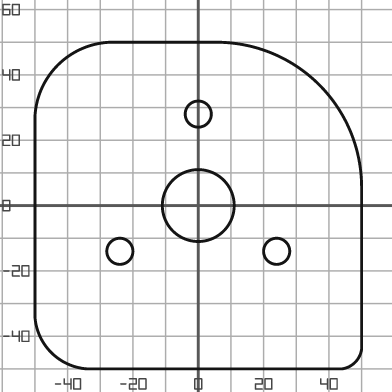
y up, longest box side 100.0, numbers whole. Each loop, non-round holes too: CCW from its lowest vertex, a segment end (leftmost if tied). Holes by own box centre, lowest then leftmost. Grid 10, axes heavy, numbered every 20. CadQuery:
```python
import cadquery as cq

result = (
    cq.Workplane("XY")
    .moveTo(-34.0, -50.0)
    .lineTo(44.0, -50.0)
    .threePointArc((48.0, -48.0), (50.0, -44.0))
    .lineTo(50.0, 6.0)
    .threePointArc((37.0, 37.0), (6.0, 50.0))
    .lineTo(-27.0, 50.0)
    .threePointArc((-43.0, 43.0), (-50.0, 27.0))
    .lineTo(-50.0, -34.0)
    .threePointArc((-45.0, -45.0), (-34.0, -50.0))
    .close()
    .moveTo(-24.0, -14.0)
    .circle(4.0)
    .moveTo(24.0, -14.0)
    .circle(4.0)
    .moveTo(0.0, 0.0)
    .circle(11.0)
    .moveTo(0.0, 28.0)
    .circle(4.0)
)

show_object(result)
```